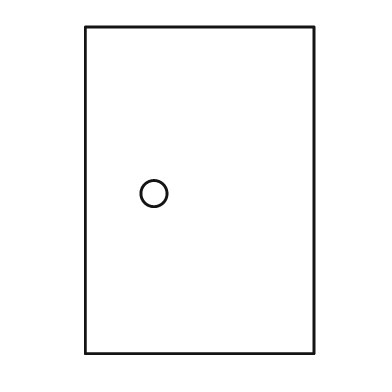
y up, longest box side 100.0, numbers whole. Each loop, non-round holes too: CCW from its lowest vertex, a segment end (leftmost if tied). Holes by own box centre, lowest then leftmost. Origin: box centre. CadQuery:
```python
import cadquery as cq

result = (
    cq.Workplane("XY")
    .moveTo(-35.0, -50.0)
    .lineTo(35.0, -50.0)
    .lineTo(35.0, 50.0)
    .lineTo(-35.0, 50.0)
    .close()
    .moveTo(-14.0, -1.0)
    .circle(4.0)
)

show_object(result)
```